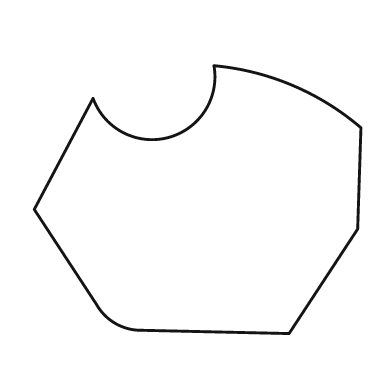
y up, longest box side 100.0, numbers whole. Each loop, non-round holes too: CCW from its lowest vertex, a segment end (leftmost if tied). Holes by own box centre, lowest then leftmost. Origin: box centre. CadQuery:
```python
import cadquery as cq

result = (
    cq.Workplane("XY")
    .moveTo(28.0, -41.0)
    .lineTo(49.0, -9.0)
    .lineTo(50.0, 22.0)
    .threePointArc((29.0, 35.0), (5.0, 41.0))
    .threePointArc((-9.0, 19.0), (-32.0, 31.0))
    .lineTo(-50.0, -3.0)
    .lineTo(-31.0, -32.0)
    .threePointArc((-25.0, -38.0), (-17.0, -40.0))
    .close()
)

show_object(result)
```